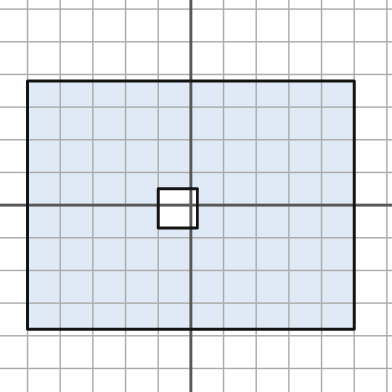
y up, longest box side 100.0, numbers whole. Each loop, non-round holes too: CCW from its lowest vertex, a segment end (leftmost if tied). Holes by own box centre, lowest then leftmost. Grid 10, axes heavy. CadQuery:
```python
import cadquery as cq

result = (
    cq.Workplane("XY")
    .moveTo(-50.0, -38.0)
    .lineTo(50.0, -38.0)
    .lineTo(50.0, 38.0)
    .lineTo(-50.0, 38.0)
    .close()
    .moveTo(-10.0, -7.0)
    .lineTo(2.0, -7.0)
    .lineTo(2.0, 5.0)
    .lineTo(-10.0, 5.0)
    .close()
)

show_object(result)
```